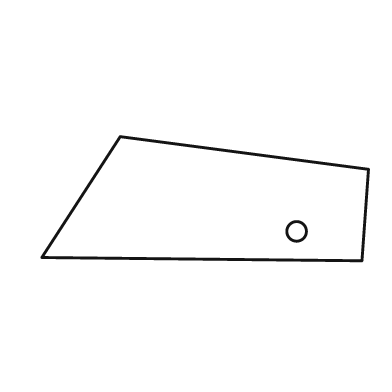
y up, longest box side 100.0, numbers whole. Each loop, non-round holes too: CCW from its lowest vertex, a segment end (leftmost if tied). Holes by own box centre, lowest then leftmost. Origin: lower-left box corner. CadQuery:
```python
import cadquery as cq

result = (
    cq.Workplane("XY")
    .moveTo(98.0, 0.0)
    .lineTo(100.0, 28.0)
    .lineTo(24.0, 38.0)
    .lineTo(0.0, 1.0)
    .close()
    .moveTo(78.0, 9.0)
    .circle(3.0)
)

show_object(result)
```